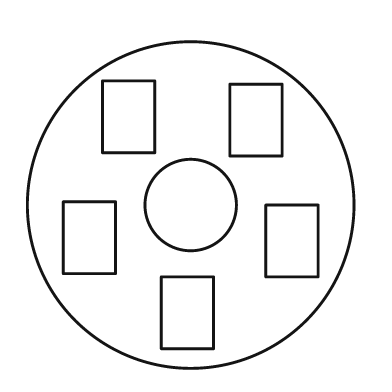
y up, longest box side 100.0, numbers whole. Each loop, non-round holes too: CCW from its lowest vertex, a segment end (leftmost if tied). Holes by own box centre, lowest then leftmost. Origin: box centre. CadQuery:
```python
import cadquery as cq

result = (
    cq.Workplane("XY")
    .moveTo(0.0, 0.0)
    .circle(50.0)
    .moveTo(-9.0, -44.0)
    .lineTo(7.0, -44.0)
    .lineTo(7.0, -22.0)
    .lineTo(-9.0, -22.0)
    .close()
    .moveTo(23.0, -22.0)
    .lineTo(39.0, -22.0)
    .lineTo(39.0, 0.0)
    .lineTo(23.0, 0.0)
    .close()
    .moveTo(-39.0, -21.0)
    .lineTo(-23.0, -21.0)
    .lineTo(-23.0, 1.0)
    .lineTo(-39.0, 1.0)
    .close()
    .moveTo(0.0, 0.0)
    .circle(14.0)
    .moveTo(12.0, 15.0)
    .lineTo(28.0, 15.0)
    .lineTo(28.0, 37.0)
    .lineTo(12.0, 37.0)
    .close()
    .moveTo(-27.0, 16.0)
    .lineTo(-11.0, 16.0)
    .lineTo(-11.0, 38.0)
    .lineTo(-27.0, 38.0)
    .close()
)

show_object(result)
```